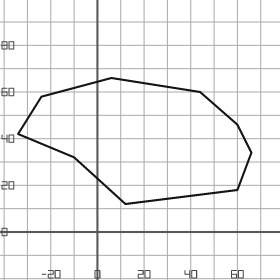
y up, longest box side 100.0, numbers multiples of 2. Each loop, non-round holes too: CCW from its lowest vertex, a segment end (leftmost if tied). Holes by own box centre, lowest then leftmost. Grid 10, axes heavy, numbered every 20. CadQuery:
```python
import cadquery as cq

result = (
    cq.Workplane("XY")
    .moveTo(12.0, 12.0)
    .lineTo(60.0, 18.0)
    .lineTo(66.0, 34.0)
    .lineTo(60.0, 46.0)
    .lineTo(44.0, 60.0)
    .lineTo(6.0, 66.0)
    .lineTo(-24.0, 58.0)
    .lineTo(-34.0, 42.0)
    .lineTo(-10.0, 32.0)
    .close()
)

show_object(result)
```